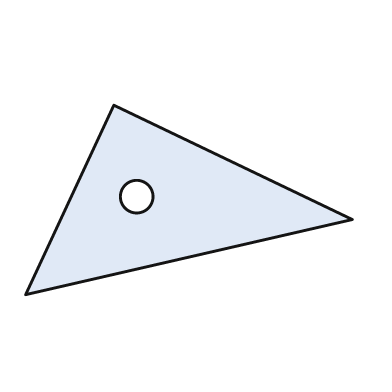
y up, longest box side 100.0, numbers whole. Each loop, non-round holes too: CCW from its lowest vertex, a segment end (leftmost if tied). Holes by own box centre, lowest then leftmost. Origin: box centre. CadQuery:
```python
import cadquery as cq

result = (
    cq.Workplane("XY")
    .moveTo(-50.0, -29.0)
    .lineTo(50.0, -6.0)
    .lineTo(-23.0, 29.0)
    .close()
    .moveTo(-16.0, 1.0)
    .circle(5.0)
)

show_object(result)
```